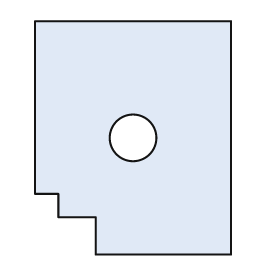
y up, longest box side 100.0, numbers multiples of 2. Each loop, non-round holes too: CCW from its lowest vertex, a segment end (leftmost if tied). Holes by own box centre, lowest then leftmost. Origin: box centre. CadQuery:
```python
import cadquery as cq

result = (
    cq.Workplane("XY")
    .moveTo(-16.0, -50.0)
    .lineTo(42.0, -50.0)
    .lineTo(42.0, 50.0)
    .lineTo(-42.0, 50.0)
    .lineTo(-42.0, -24.0)
    .lineTo(-32.0, -24.0)
    .lineTo(-32.0, -34.0)
    .lineTo(-16.0, -34.0)
    .close()
    .moveTo(0.0, 0.0)
    .circle(10.0)
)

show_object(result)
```